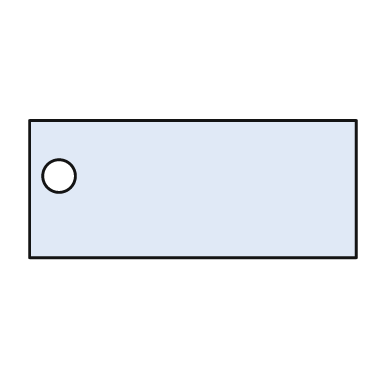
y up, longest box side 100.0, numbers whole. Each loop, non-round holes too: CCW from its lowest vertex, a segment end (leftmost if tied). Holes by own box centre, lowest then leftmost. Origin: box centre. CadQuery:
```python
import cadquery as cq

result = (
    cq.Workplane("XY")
    .moveTo(-50.0, -21.0)
    .lineTo(50.0, -21.0)
    .lineTo(50.0, 21.0)
    .lineTo(-50.0, 21.0)
    .close()
    .moveTo(-41.0, 4.0)
    .circle(5.0)
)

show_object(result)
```